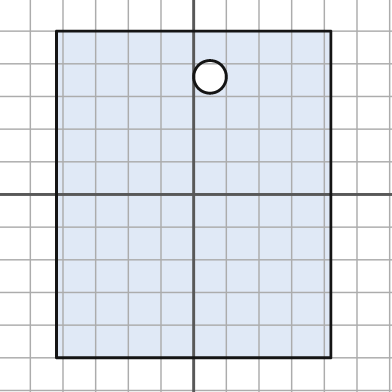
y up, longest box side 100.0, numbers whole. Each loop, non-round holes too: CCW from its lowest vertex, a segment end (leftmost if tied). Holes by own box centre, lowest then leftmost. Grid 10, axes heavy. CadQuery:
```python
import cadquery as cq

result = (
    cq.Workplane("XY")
    .moveTo(-42.0, -50.0)
    .lineTo(42.0, -50.0)
    .lineTo(42.0, 50.0)
    .lineTo(-42.0, 50.0)
    .close()
    .moveTo(5.0, 36.0)
    .circle(5.0)
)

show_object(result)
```